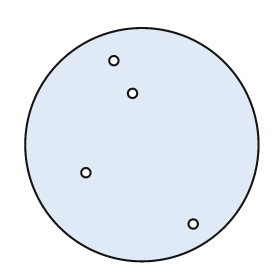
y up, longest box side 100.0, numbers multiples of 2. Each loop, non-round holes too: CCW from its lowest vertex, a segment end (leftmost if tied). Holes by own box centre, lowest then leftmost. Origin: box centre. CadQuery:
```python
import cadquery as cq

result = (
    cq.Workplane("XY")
    .moveTo(0.0, 0.0)
    .circle(50.0)
    .moveTo(22.0, -34.0)
    .circle(2.0)
    .moveTo(-24.0, -12.0)
    .circle(2.0)
    .moveTo(-4.0, 22.0)
    .circle(2.0)
    .moveTo(-12.0, 36.0)
    .circle(2.0)
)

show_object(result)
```